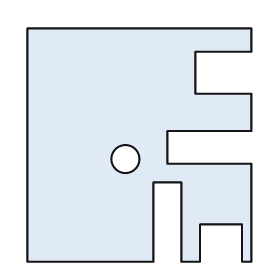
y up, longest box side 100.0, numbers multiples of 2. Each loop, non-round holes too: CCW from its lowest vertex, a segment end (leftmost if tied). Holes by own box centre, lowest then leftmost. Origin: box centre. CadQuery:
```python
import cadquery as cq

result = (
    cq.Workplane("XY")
    .moveTo(-48.0, -50.0)
    .lineTo(6.0, -50.0)
    .lineTo(6.0, -16.0)
    .lineTo(18.0, -16.0)
    .lineTo(18.0, -50.0)
    .lineTo(26.0, -50.0)
    .lineTo(26.0, -34.0)
    .lineTo(44.0, -34.0)
    .lineTo(44.0, -50.0)
    .lineTo(48.0, -50.0)
    .lineTo(48.0, -8.0)
    .lineTo(12.0, -8.0)
    .lineTo(12.0, 6.0)
    .lineTo(48.0, 6.0)
    .lineTo(48.0, 22.0)
    .lineTo(24.0, 22.0)
    .lineTo(24.0, 40.0)
    .lineTo(48.0, 40.0)
    .lineTo(48.0, 50.0)
    .lineTo(-48.0, 50.0)
    .close()
    .moveTo(-6.0, -6.0)
    .circle(6.0)
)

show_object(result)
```